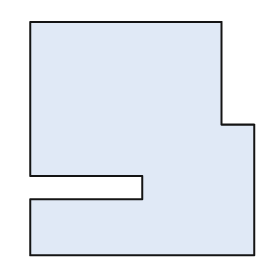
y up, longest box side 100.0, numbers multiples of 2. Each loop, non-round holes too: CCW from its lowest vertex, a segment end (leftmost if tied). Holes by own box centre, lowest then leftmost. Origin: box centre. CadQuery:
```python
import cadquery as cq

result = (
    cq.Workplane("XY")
    .moveTo(-48.0, -50.0)
    .lineTo(48.0, -50.0)
    .lineTo(48.0, 6.0)
    .lineTo(34.0, 6.0)
    .lineTo(34.0, 50.0)
    .lineTo(-48.0, 50.0)
    .lineTo(-48.0, -16.0)
    .lineTo(0.0, -16.0)
    .lineTo(0.0, -26.0)
    .lineTo(-48.0, -26.0)
    .close()
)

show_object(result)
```